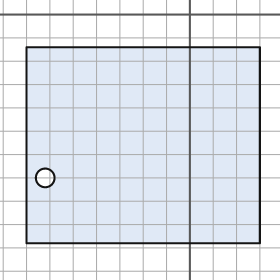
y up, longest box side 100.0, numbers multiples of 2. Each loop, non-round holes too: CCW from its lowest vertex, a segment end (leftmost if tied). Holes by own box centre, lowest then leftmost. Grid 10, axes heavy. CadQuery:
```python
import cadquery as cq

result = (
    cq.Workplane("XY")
    .moveTo(-70.0, -98.0)
    .lineTo(30.0, -98.0)
    .lineTo(30.0, -14.0)
    .lineTo(-70.0, -14.0)
    .close()
    .moveTo(-62.0, -70.0)
    .circle(4.0)
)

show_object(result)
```